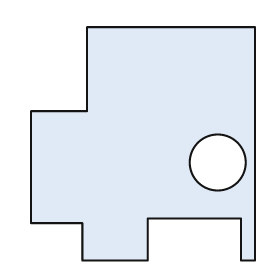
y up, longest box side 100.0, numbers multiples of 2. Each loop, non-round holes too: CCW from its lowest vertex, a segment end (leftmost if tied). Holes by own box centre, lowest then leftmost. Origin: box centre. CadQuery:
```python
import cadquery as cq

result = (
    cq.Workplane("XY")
    .moveTo(-26.0, -50.0)
    .lineTo(2.0, -50.0)
    .lineTo(2.0, -32.0)
    .lineTo(42.0, -32.0)
    .lineTo(42.0, -50.0)
    .lineTo(48.0, -50.0)
    .lineTo(48.0, 50.0)
    .lineTo(-24.0, 50.0)
    .lineTo(-24.0, 14.0)
    .lineTo(-48.0, 14.0)
    .lineTo(-48.0, -34.0)
    .lineTo(-26.0, -34.0)
    .close()
    .moveTo(32.0, -8.0)
    .circle(12.0)
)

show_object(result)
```